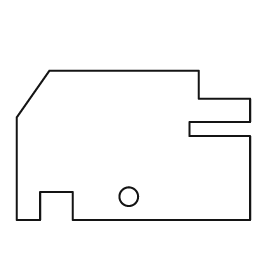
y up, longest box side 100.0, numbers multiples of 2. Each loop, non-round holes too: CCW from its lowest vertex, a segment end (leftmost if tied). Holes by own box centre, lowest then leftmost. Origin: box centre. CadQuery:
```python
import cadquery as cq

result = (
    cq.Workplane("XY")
    .moveTo(-50.0, -32.0)
    .lineTo(-40.0, -32.0)
    .lineTo(-40.0, -20.0)
    .lineTo(-26.0, -20.0)
    .lineTo(-26.0, -32.0)
    .lineTo(50.0, -32.0)
    .lineTo(50.0, 4.0)
    .lineTo(24.0, 4.0)
    .lineTo(24.0, 10.0)
    .lineTo(50.0, 10.0)
    .lineTo(50.0, 20.0)
    .lineTo(28.0, 20.0)
    .lineTo(28.0, 32.0)
    .lineTo(-36.0, 32.0)
    .lineTo(-50.0, 12.0)
    .close()
    .moveTo(-2.0, -22.0)
    .circle(4.0)
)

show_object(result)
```